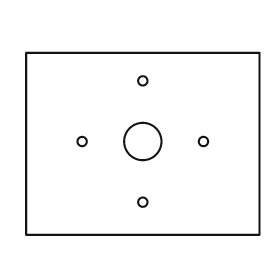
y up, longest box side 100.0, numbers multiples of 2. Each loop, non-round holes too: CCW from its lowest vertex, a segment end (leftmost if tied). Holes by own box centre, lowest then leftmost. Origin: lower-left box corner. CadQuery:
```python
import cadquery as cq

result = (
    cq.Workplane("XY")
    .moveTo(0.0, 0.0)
    .lineTo(100.0, 0.0)
    .lineTo(100.0, 78.0)
    .lineTo(0.0, 78.0)
    .close()
    .moveTo(50.0, 14.0)
    .circle(2.0)
    .moveTo(24.0, 40.0)
    .circle(2.0)
    .moveTo(50.0, 40.0)
    .circle(8.0)
    .moveTo(76.0, 40.0)
    .circle(2.0)
    .moveTo(50.0, 66.0)
    .circle(2.0)
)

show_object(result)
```